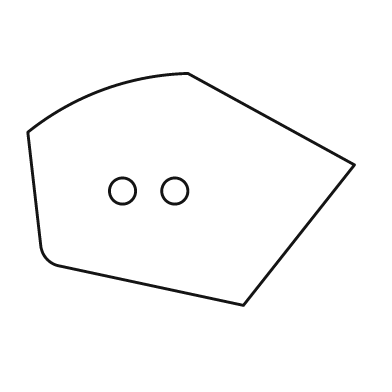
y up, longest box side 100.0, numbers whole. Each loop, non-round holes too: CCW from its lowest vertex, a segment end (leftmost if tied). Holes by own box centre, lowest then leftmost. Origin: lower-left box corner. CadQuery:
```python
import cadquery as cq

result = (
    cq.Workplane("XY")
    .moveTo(66.0, 0.0)
    .lineTo(100.0, 43.0)
    .lineTo(49.0, 71.0)
    .threePointArc((23.0, 66.0), (0.0, 53.0))
    .lineTo(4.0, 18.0)
    .threePointArc((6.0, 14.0), (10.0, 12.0))
    .close()
    .moveTo(29.0, 35.0)
    .circle(4.0)
    .moveTo(45.0, 35.0)
    .circle(4.0)
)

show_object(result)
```